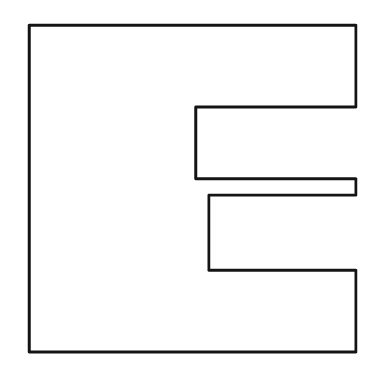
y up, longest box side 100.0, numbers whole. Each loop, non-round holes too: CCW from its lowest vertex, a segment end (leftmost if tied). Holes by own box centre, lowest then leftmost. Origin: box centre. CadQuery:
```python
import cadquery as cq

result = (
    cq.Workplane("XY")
    .moveTo(-50.0, -50.0)
    .lineTo(50.0, -50.0)
    .lineTo(50.0, -25.0)
    .lineTo(5.0, -25.0)
    .lineTo(5.0, -2.0)
    .lineTo(50.0, -2.0)
    .lineTo(50.0, 3.0)
    .lineTo(1.0, 3.0)
    .lineTo(1.0, 25.0)
    .lineTo(50.0, 25.0)
    .lineTo(50.0, 50.0)
    .lineTo(-50.0, 50.0)
    .close()
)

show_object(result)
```